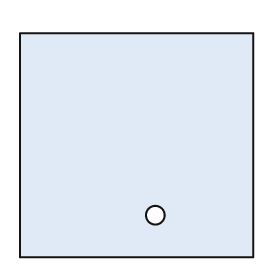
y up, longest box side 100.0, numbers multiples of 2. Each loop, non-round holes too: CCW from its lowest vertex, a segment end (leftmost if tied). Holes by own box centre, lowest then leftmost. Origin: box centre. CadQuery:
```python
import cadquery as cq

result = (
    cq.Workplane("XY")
    .moveTo(-50.0, -48.0)
    .lineTo(50.0, -48.0)
    .lineTo(50.0, 48.0)
    .lineTo(-50.0, 48.0)
    .close()
    .moveTo(8.0, -30.0)
    .circle(4.0)
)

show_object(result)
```